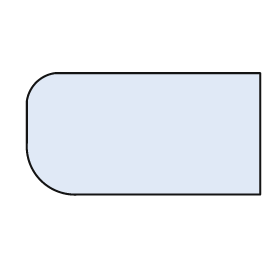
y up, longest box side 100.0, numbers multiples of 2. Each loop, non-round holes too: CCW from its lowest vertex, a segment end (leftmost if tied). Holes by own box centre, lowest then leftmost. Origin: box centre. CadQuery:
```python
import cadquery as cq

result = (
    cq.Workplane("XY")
    .moveTo(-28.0, -26.0)
    .lineTo(50.0, -26.0)
    .lineTo(50.0, 26.0)
    .lineTo(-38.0, 26.0)
    .threePointArc((-46.0, 22.0), (-50.0, 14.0))
    .lineTo(-50.0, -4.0)
    .threePointArc((-44.0, -20.0), (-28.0, -26.0))
    .close()
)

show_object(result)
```